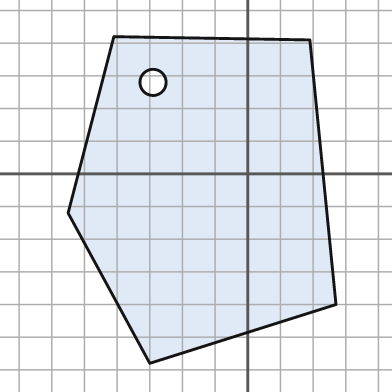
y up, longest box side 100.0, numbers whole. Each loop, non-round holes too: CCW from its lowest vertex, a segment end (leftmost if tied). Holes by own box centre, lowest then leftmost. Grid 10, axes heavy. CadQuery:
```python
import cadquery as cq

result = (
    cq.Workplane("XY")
    .moveTo(-30.0, -58.0)
    .lineTo(27.0, -40.0)
    .lineTo(19.0, 41.0)
    .lineTo(-41.0, 42.0)
    .lineTo(-55.0, -12.0)
    .close()
    .moveTo(-29.0, 28.0)
    .circle(4.0)
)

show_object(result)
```